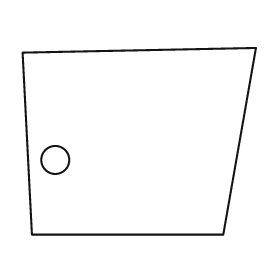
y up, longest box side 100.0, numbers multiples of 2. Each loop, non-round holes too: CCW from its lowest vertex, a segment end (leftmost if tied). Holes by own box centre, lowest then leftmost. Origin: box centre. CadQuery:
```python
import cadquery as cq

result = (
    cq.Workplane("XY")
    .moveTo(-46.0, -40.0)
    .lineTo(36.0, -40.0)
    .lineTo(50.0, 40.0)
    .lineTo(-50.0, 38.0)
    .close()
    .moveTo(-36.0, -8.0)
    .circle(6.0)
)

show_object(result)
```